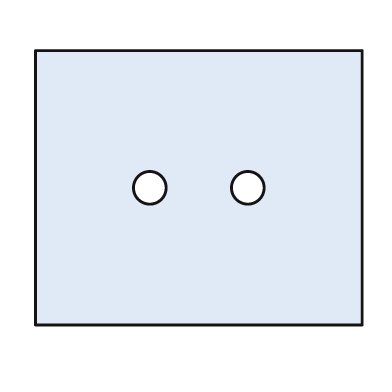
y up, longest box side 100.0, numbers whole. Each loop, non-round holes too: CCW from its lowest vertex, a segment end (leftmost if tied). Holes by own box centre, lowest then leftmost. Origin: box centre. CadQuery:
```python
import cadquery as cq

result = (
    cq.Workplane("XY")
    .moveTo(-50.0, -42.0)
    .lineTo(50.0, -42.0)
    .lineTo(50.0, 42.0)
    .lineTo(-50.0, 42.0)
    .close()
    .moveTo(-15.0, 0.0)
    .circle(5.0)
    .moveTo(15.0, 0.0)
    .circle(5.0)
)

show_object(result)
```